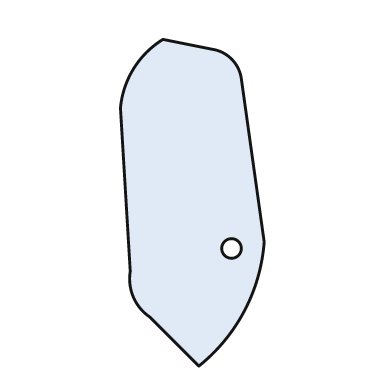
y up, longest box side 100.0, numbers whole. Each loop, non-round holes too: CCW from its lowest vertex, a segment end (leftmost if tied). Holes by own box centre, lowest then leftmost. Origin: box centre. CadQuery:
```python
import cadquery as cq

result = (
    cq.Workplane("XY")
    .moveTo(2.0, -50.0)
    .threePointArc((16.0, -33.0), (22.0, -12.0))
    .lineTo(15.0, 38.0)
    .threePointArc((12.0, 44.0), (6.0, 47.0))
    .lineTo(-9.0, 50.0)
    .threePointArc((-18.0, 41.0), (-22.0, 29.0))
    .lineTo(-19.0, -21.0)
    .threePointArc((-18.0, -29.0), (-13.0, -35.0))
    .close()
    .moveTo(12.0, -14.0)
    .circle(3.0)
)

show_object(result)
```